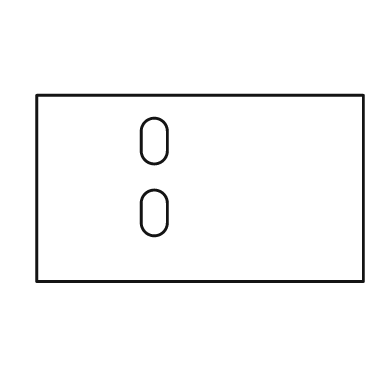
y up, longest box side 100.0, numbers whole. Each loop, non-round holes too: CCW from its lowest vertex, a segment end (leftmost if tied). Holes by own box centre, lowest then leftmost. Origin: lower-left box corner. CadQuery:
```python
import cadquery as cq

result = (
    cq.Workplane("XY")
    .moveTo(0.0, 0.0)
    .lineTo(100.0, 0.0)
    .lineTo(100.0, 57.0)
    .lineTo(0.0, 57.0)
    .close()
    .moveTo(32.0, 18.0)
    .threePointArc((36.0, 14.0), (40.0, 18.0))
    .lineTo(40.0, 24.0)
    .threePointArc((36.0, 28.0), (32.0, 24.0))
    .close()
    .moveTo(32.0, 40.0)
    .threePointArc((36.0, 36.0), (40.0, 40.0))
    .lineTo(40.0, 46.0)
    .threePointArc((36.0, 50.0), (32.0, 46.0))
    .close()
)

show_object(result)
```